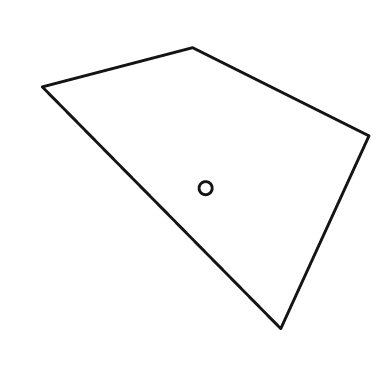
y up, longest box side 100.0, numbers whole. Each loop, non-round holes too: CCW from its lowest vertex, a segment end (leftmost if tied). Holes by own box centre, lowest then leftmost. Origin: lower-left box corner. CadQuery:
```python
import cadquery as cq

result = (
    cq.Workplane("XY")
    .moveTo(73.0, 0.0)
    .lineTo(100.0, 59.0)
    .lineTo(46.0, 86.0)
    .lineTo(0.0, 74.0)
    .close()
    .moveTo(50.0, 43.0)
    .circle(2.0)
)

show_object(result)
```